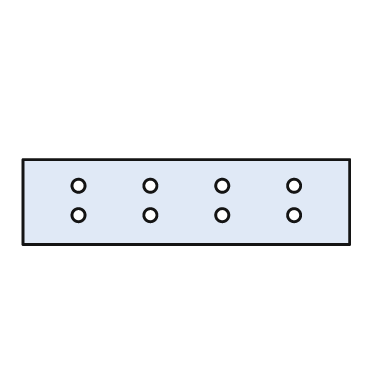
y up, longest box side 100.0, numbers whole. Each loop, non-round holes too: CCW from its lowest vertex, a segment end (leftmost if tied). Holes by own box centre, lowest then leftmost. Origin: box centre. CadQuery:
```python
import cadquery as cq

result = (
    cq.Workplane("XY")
    .moveTo(-50.0, -13.0)
    .lineTo(50.0, -13.0)
    .lineTo(50.0, 13.0)
    .lineTo(-50.0, 13.0)
    .close()
    .moveTo(-33.0, -4.0)
    .circle(2.0)
    .moveTo(-11.0, -4.0)
    .circle(2.0)
    .moveTo(11.0, -4.0)
    .circle(2.0)
    .moveTo(33.0, -4.0)
    .circle(2.0)
    .moveTo(-33.0, 5.0)
    .circle(2.0)
    .moveTo(-11.0, 5.0)
    .circle(2.0)
    .moveTo(11.0, 5.0)
    .circle(2.0)
    .moveTo(33.0, 5.0)
    .circle(2.0)
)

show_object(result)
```